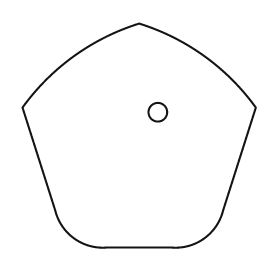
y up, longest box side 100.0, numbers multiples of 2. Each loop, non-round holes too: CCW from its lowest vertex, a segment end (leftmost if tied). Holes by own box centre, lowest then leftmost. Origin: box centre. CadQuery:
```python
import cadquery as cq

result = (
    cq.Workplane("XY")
    .moveTo(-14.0, -48.0)
    .lineTo(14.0, -48.0)
    .threePointArc((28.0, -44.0), (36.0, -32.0))
    .lineTo(50.0, 12.0)
    .threePointArc((28.0, 34.0), (0.0, 48.0))
    .threePointArc((-28.0, 34.0), (-50.0, 12.0))
    .lineTo(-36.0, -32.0)
    .threePointArc((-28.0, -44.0), (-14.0, -48.0))
    .close()
    .moveTo(8.0, 10.0)
    .circle(4.0)
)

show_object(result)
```